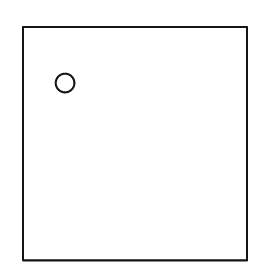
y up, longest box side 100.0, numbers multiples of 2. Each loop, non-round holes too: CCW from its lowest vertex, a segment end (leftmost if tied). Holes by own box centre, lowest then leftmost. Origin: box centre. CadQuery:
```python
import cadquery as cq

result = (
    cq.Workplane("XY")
    .moveTo(-48.0, -50.0)
    .lineTo(48.0, -50.0)
    .lineTo(48.0, 50.0)
    .lineTo(-48.0, 50.0)
    .close()
    .moveTo(-30.0, 26.0)
    .circle(4.0)
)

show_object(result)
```